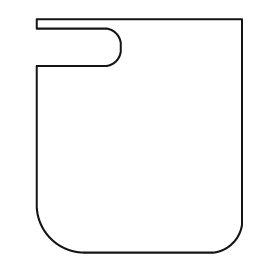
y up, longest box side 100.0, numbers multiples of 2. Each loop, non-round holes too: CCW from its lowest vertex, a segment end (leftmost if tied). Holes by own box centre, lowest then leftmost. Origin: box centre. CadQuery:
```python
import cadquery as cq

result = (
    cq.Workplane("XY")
    .moveTo(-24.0, -50.0)
    .lineTo(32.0, -50.0)
    .threePointArc((40.0, -46.0), (44.0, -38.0))
    .lineTo(44.0, 50.0)
    .lineTo(-44.0, 50.0)
    .lineTo(-44.0, 46.0)
    .lineTo(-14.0, 46.0)
    .threePointArc((-10.0, 44.0), (-8.0, 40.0))
    .lineTo(-8.0, 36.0)
    .threePointArc((-10.0, 32.0), (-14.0, 30.0))
    .lineTo(-44.0, 30.0)
    .lineTo(-44.0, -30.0)
    .threePointArc((-38.0, -44.0), (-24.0, -50.0))
    .close()
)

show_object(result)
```